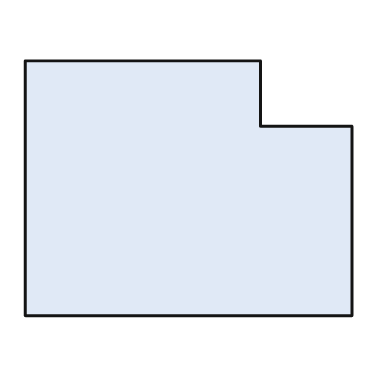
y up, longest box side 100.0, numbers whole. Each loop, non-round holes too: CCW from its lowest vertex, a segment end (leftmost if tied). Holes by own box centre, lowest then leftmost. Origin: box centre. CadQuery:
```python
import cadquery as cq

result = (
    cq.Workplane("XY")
    .moveTo(-50.0, -39.0)
    .lineTo(50.0, -39.0)
    .lineTo(50.0, 19.0)
    .lineTo(22.0, 19.0)
    .lineTo(22.0, 39.0)
    .lineTo(-50.0, 39.0)
    .close()
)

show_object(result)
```